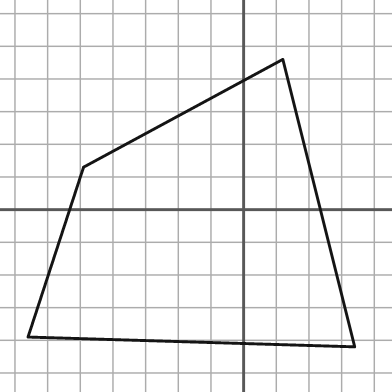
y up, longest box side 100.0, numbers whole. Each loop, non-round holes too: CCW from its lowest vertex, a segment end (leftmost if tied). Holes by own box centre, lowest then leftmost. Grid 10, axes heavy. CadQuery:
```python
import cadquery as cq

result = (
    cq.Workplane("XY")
    .moveTo(34.0, -42.0)
    .lineTo(12.0, 46.0)
    .lineTo(-49.0, 13.0)
    .lineTo(-66.0, -39.0)
    .close()
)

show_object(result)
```